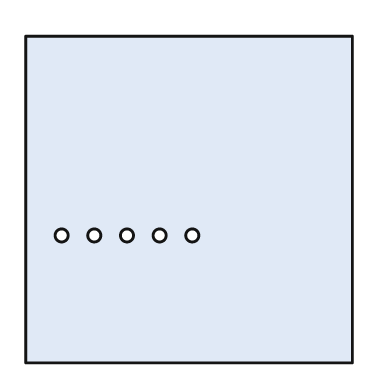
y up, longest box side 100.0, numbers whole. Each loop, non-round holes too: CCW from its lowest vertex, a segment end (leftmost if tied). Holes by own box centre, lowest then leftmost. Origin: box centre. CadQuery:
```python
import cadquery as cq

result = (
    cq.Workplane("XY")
    .moveTo(-50.0, -50.0)
    .lineTo(50.0, -50.0)
    .lineTo(50.0, 50.0)
    .lineTo(-50.0, 50.0)
    .close()
    .moveTo(-39.0, -11.0)
    .circle(2.0)
    .moveTo(-29.0, -11.0)
    .circle(2.0)
    .moveTo(-19.0, -11.0)
    .circle(2.0)
    .moveTo(-9.0, -11.0)
    .circle(2.0)
    .moveTo(1.0, -11.0)
    .circle(2.0)
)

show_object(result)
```